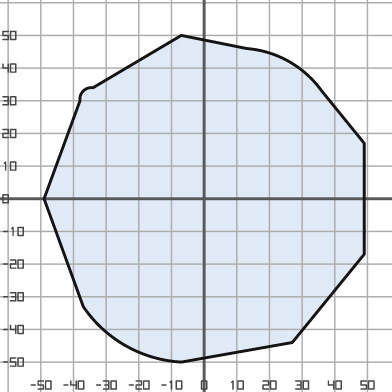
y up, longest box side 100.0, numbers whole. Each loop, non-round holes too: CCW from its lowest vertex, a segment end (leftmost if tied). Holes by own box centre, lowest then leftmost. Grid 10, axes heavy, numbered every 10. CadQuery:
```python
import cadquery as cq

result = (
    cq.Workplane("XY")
    .moveTo(-7.0, -50.0)
    .lineTo(27.0, -44.0)
    .lineTo(49.0, -17.0)
    .lineTo(49.0, 17.0)
    .lineTo(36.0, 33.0)
    .threePointArc((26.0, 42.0), (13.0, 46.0))
    .lineTo(-7.0, 50.0)
    .lineTo(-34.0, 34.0)
    .threePointArc((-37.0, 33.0), (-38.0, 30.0))
    .lineTo(-49.0, 0.0)
    .lineTo(-37.0, -33.0)
    .threePointArc((-24.0, -45.0), (-7.0, -50.0))
    .close()
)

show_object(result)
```